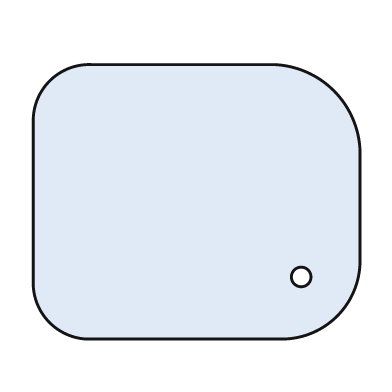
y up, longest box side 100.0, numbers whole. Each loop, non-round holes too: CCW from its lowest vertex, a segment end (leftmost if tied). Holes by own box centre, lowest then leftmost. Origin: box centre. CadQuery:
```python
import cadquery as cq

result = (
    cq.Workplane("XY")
    .moveTo(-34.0, -42.0)
    .lineTo(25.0, -42.0)
    .threePointArc((43.0, -35.0), (50.0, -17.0))
    .lineTo(50.0, 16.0)
    .threePointArc((42.0, 34.0), (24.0, 42.0))
    .lineTo(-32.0, 42.0)
    .threePointArc((-45.0, 37.0), (-50.0, 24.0))
    .lineTo(-50.0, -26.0)
    .threePointArc((-45.0, -37.0), (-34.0, -42.0))
    .close()
    .moveTo(32.0, -23.0)
    .circle(3.0)
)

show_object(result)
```